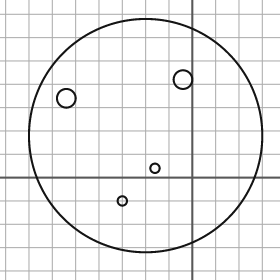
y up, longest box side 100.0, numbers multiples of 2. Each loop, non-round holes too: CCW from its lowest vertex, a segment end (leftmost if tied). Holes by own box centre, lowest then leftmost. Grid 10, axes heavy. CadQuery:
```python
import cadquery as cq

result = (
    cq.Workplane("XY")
    .moveTo(-20.0, 18.0)
    .circle(50.0)
    .moveTo(-30.0, -10.0)
    .circle(2.0)
    .moveTo(-16.0, 4.0)
    .circle(2.0)
    .moveTo(-54.0, 34.0)
    .circle(4.0)
    .moveTo(-4.0, 42.0)
    .circle(4.0)
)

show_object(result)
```